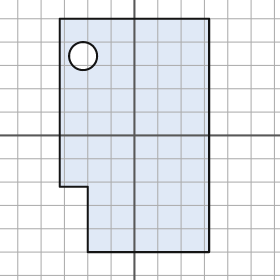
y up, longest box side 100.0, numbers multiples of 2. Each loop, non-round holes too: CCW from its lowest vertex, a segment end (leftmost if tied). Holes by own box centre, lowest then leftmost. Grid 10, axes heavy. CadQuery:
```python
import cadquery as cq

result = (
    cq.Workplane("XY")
    .moveTo(-20.0, -50.0)
    .lineTo(32.0, -50.0)
    .lineTo(32.0, 50.0)
    .lineTo(-32.0, 50.0)
    .lineTo(-32.0, -22.0)
    .lineTo(-20.0, -22.0)
    .close()
    .moveTo(-22.0, 34.0)
    .circle(6.0)
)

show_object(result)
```